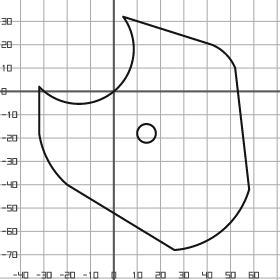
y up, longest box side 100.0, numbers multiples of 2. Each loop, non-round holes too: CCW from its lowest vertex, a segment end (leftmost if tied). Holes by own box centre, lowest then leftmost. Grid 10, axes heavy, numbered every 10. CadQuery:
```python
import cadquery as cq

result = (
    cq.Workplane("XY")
    .moveTo(26.0, -68.0)
    .threePointArc((46.0, -60.0), (58.0, -42.0))
    .lineTo(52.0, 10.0)
    .threePointArc((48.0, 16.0), (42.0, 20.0))
    .lineTo(4.0, 32.0)
    .threePointArc((0.0, 0.0), (-32.0, 2.0))
    .lineTo(-32.0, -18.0)
    .threePointArc((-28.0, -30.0), (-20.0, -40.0))
    .close()
    .moveTo(14.0, -18.0)
    .circle(4.0)
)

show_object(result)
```